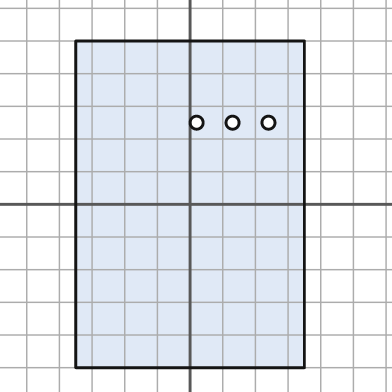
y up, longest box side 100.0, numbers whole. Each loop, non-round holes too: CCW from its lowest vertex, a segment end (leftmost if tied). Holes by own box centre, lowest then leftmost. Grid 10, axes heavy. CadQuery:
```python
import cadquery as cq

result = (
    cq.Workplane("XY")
    .moveTo(-35.0, -50.0)
    .lineTo(35.0, -50.0)
    .lineTo(35.0, 50.0)
    .lineTo(-35.0, 50.0)
    .close()
    .moveTo(2.0, 25.0)
    .circle(2.0)
    .moveTo(13.0, 25.0)
    .circle(2.0)
    .moveTo(24.0, 25.0)
    .circle(2.0)
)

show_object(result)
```